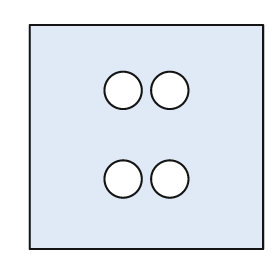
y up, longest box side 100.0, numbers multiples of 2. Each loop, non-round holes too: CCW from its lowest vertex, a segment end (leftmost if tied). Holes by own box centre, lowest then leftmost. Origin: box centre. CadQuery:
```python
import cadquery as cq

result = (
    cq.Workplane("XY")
    .moveTo(-50.0, -48.0)
    .lineTo(50.0, -48.0)
    .lineTo(50.0, 48.0)
    .lineTo(-50.0, 48.0)
    .close()
    .moveTo(-10.0, -18.0)
    .circle(8.0)
    .moveTo(10.0, -18.0)
    .circle(8.0)
    .moveTo(-10.0, 20.0)
    .circle(8.0)
    .moveTo(10.0, 20.0)
    .circle(8.0)
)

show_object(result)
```